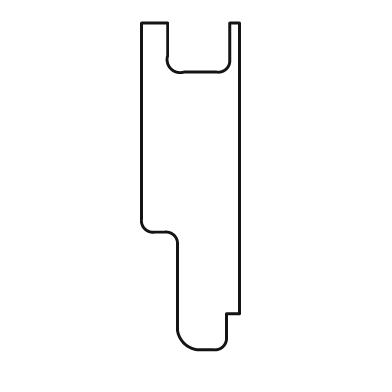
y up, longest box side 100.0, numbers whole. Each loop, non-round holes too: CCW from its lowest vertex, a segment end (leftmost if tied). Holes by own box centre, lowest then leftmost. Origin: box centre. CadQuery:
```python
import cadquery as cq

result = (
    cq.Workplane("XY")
    .moveTo(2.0, -50.0)
    .lineTo(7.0, -50.0)
    .threePointArc((10.0, -49.0), (11.0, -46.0))
    .lineTo(11.0, -39.0)
    .lineTo(15.0, -39.0)
    .lineTo(15.0, 50.0)
    .lineTo(12.0, 50.0)
    .lineTo(12.0, 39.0)
    .threePointArc((11.0, 36.0), (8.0, 35.0))
    .lineTo(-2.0, 35.0)
    .threePointArc((-6.0, 36.0), (-7.0, 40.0))
    .lineTo(-7.0, 50.0)
    .lineTo(-15.0, 50.0)
    .lineTo(-15.0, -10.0)
    .threePointArc((-14.0, -13.0), (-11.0, -14.0))
    .lineTo(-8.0, -14.0)
    .threePointArc((-5.0, -15.0), (-4.0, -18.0))
    .lineTo(-4.0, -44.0)
    .threePointArc((-2.0, -48.0), (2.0, -50.0))
    .close()
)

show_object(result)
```